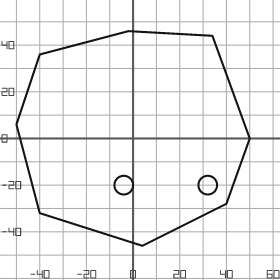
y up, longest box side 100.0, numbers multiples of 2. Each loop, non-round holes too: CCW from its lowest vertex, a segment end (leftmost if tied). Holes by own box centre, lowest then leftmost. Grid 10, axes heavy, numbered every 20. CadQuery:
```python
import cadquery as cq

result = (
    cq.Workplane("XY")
    .moveTo(4.0, -46.0)
    .lineTo(40.0, -28.0)
    .lineTo(50.0, 0.0)
    .lineTo(34.0, 44.0)
    .lineTo(-2.0, 46.0)
    .lineTo(-40.0, 36.0)
    .lineTo(-50.0, 6.0)
    .lineTo(-40.0, -32.0)
    .close()
    .moveTo(-4.0, -20.0)
    .circle(4.0)
    .moveTo(32.0, -20.0)
    .circle(4.0)
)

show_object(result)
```